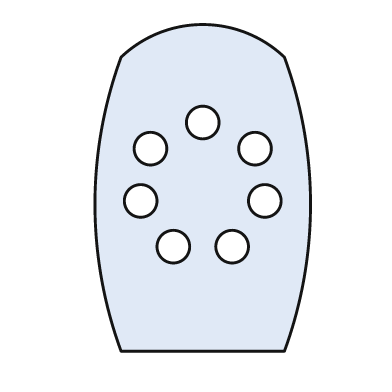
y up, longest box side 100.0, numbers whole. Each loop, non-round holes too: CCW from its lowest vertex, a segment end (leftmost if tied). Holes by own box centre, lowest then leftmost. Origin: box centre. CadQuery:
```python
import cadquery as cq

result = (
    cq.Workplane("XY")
    .moveTo(-25.0, -50.0)
    .lineTo(25.0, -50.0)
    .threePointArc((33.0, -5.0), (25.0, 40.0))
    .threePointArc((0.0, 50.0), (-25.0, 40.0))
    .threePointArc((-33.0, -5.0), (-25.0, -50.0))
    .close()
    .moveTo(-9.0, -18.0)
    .circle(5.0)
    .moveTo(9.0, -18.0)
    .circle(5.0)
    .moveTo(-19.0, -4.0)
    .circle(5.0)
    .moveTo(19.0, -4.0)
    .circle(5.0)
    .moveTo(-16.0, 12.0)
    .circle(5.0)
    .moveTo(16.0, 12.0)
    .circle(5.0)
    .moveTo(0.0, 20.0)
    .circle(5.0)
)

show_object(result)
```